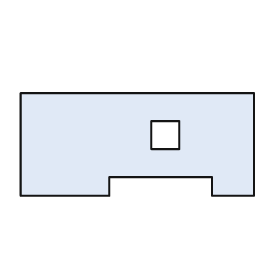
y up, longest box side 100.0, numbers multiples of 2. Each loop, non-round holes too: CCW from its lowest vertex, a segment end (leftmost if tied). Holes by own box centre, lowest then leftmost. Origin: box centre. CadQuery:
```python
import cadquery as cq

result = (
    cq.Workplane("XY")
    .moveTo(-50.0, -22.0)
    .lineTo(-12.0, -22.0)
    .lineTo(-12.0, -14.0)
    .lineTo(32.0, -14.0)
    .lineTo(32.0, -22.0)
    .lineTo(50.0, -22.0)
    .lineTo(50.0, 22.0)
    .lineTo(-50.0, 22.0)
    .close()
    .moveTo(6.0, -2.0)
    .lineTo(18.0, -2.0)
    .lineTo(18.0, 10.0)
    .lineTo(6.0, 10.0)
    .close()
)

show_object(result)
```